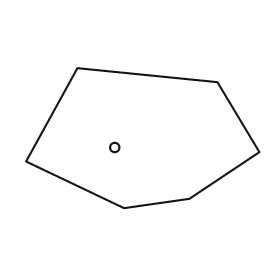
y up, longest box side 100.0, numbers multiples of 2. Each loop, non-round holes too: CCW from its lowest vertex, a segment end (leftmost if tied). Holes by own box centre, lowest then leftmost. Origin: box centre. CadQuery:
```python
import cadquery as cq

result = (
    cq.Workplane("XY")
    .moveTo(-8.0, -30.0)
    .lineTo(20.0, -26.0)
    .lineTo(50.0, -6.0)
    .lineTo(32.0, 24.0)
    .lineTo(-28.0, 30.0)
    .lineTo(-50.0, -10.0)
    .close()
    .moveTo(-12.0, -4.0)
    .circle(2.0)
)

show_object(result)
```